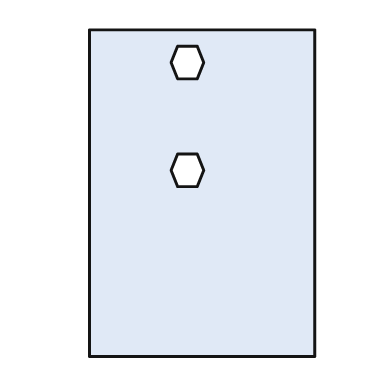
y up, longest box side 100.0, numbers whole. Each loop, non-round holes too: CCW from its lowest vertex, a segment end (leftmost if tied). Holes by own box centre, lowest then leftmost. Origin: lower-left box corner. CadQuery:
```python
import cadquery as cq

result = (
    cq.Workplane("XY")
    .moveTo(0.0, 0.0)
    .lineTo(69.0, 0.0)
    .lineTo(69.0, 100.0)
    .lineTo(0.0, 100.0)
    .close()
    .moveTo(27.0, 52.0)
    .lineTo(33.0, 52.0)
    .lineTo(35.0, 57.0)
    .lineTo(33.0, 62.0)
    .lineTo(27.0, 62.0)
    .lineTo(25.0, 57.0)
    .close()
    .moveTo(27.0, 85.0)
    .lineTo(33.0, 85.0)
    .lineTo(35.0, 90.0)
    .lineTo(33.0, 95.0)
    .lineTo(27.0, 95.0)
    .lineTo(25.0, 90.0)
    .close()
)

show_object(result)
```